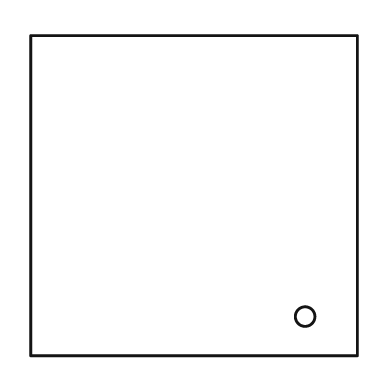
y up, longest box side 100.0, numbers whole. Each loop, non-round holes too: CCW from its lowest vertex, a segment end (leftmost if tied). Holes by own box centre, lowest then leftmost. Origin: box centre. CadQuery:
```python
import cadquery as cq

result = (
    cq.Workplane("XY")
    .moveTo(-50.0, -49.0)
    .lineTo(50.0, -49.0)
    .lineTo(50.0, 49.0)
    .lineTo(-50.0, 49.0)
    .close()
    .moveTo(34.0, -37.0)
    .circle(3.0)
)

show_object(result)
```